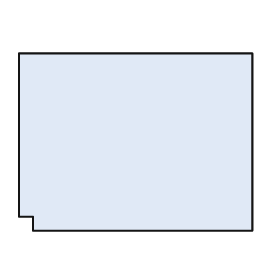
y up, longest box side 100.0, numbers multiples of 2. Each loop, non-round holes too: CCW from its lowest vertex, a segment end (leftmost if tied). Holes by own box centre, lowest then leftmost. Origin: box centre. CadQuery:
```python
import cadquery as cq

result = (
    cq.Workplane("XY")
    .moveTo(-44.0, -38.0)
    .lineTo(50.0, -38.0)
    .lineTo(50.0, 38.0)
    .lineTo(-50.0, 38.0)
    .lineTo(-50.0, -32.0)
    .lineTo(-44.0, -32.0)
    .close()
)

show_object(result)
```